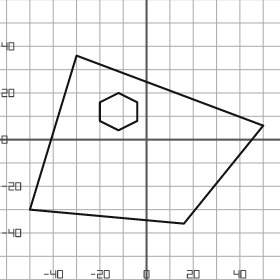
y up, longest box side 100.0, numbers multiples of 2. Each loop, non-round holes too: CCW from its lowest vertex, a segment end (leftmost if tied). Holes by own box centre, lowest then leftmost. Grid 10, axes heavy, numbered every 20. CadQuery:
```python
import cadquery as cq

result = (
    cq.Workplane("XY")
    .moveTo(16.0, -36.0)
    .lineTo(50.0, 6.0)
    .lineTo(-30.0, 36.0)
    .lineTo(-50.0, -30.0)
    .close()
    .moveTo(-12.0, 4.0)
    .lineTo(-4.0, 8.0)
    .lineTo(-4.0, 16.0)
    .lineTo(-12.0, 20.0)
    .lineTo(-20.0, 16.0)
    .lineTo(-20.0, 8.0)
    .close()
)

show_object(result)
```